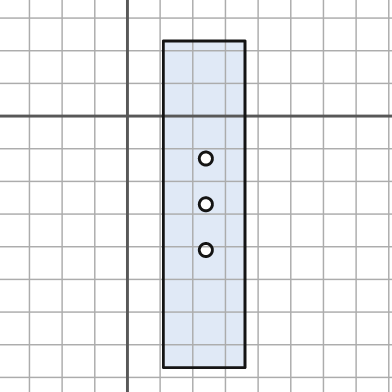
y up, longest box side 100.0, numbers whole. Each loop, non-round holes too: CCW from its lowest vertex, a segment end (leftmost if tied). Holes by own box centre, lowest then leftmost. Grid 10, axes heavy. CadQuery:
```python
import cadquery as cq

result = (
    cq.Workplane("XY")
    .moveTo(11.0, -77.0)
    .lineTo(36.0, -77.0)
    .lineTo(36.0, 23.0)
    .lineTo(11.0, 23.0)
    .close()
    .moveTo(24.0, -41.0)
    .circle(2.0)
    .moveTo(24.0, -27.0)
    .circle(2.0)
    .moveTo(24.0, -13.0)
    .circle(2.0)
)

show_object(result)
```